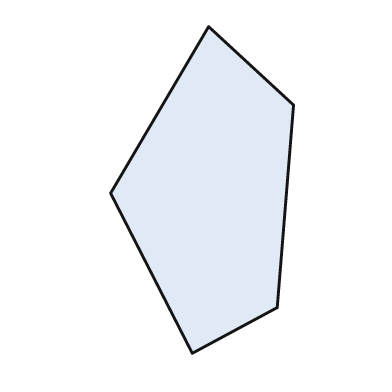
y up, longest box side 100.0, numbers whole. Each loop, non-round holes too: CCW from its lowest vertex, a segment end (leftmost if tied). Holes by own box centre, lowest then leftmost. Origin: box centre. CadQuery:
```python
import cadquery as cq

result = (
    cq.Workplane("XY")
    .moveTo(-3.0, -50.0)
    .lineTo(23.0, -36.0)
    .lineTo(28.0, 26.0)
    .lineTo(2.0, 50.0)
    .lineTo(-28.0, -1.0)
    .close()
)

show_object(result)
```